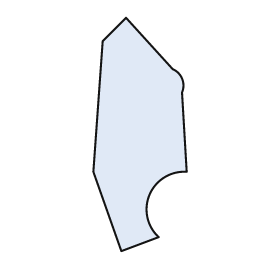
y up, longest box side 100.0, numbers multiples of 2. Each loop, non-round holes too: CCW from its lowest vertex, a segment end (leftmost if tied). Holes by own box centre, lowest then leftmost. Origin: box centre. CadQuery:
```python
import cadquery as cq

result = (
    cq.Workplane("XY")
    .moveTo(-8.0, -50.0)
    .lineTo(8.0, -44.0)
    .threePointArc((4.0, -26.0), (20.0, -16.0))
    .lineTo(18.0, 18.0)
    .threePointArc((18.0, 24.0), (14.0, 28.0))
    .lineTo(-6.0, 50.0)
    .lineTo(-16.0, 40.0)
    .lineTo(-20.0, -16.0)
    .close()
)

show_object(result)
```